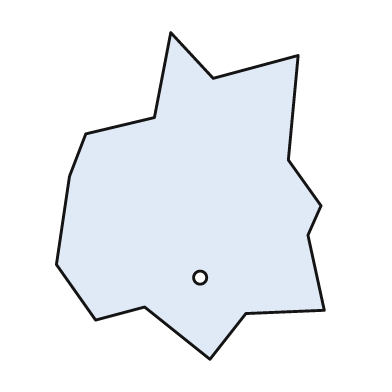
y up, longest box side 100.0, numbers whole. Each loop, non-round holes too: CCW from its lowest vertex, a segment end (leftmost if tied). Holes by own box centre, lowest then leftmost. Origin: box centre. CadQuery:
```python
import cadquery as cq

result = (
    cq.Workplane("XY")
    .moveTo(6.0, -50.0)
    .lineTo(17.0, -36.0)
    .lineTo(41.0, -35.0)
    .lineTo(36.0, -12.0)
    .lineTo(40.0, -3.0)
    .lineTo(30.0, 11.0)
    .lineTo(33.0, 43.0)
    .lineTo(7.0, 36.0)
    .lineTo(-6.0, 50.0)
    .lineTo(-11.0, 24.0)
    .lineTo(-32.0, 19.0)
    .lineTo(-37.0, 6.0)
    .lineTo(-41.0, -21.0)
    .lineTo(-29.0, -38.0)
    .lineTo(-14.0, -34.0)
    .close()
    .moveTo(3.0, -25.0)
    .circle(2.0)
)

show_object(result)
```